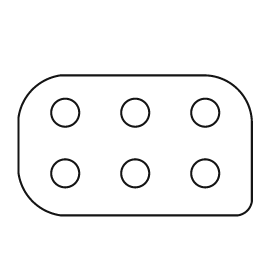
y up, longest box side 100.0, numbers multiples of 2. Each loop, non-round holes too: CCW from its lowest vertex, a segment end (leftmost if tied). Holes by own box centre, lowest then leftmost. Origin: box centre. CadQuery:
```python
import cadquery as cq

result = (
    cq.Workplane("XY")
    .moveTo(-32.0, -30.0)
    .lineTo(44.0, -30.0)
    .threePointArc((48.0, -28.0), (50.0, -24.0))
    .lineTo(50.0, 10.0)
    .threePointArc((44.0, 24.0), (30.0, 30.0))
    .lineTo(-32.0, 30.0)
    .threePointArc((-44.0, 24.0), (-50.0, 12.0))
    .lineTo(-50.0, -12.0)
    .threePointArc((-44.0, -24.0), (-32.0, -30.0))
    .close()
    .moveTo(-30.0, -12.0)
    .circle(6.0)
    .moveTo(0.0, -12.0)
    .circle(6.0)
    .moveTo(30.0, -12.0)
    .circle(6.0)
    .moveTo(-30.0, 14.0)
    .circle(6.0)
    .moveTo(0.0, 14.0)
    .circle(6.0)
    .moveTo(30.0, 14.0)
    .circle(6.0)
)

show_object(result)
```